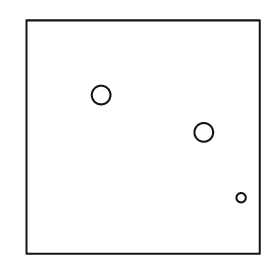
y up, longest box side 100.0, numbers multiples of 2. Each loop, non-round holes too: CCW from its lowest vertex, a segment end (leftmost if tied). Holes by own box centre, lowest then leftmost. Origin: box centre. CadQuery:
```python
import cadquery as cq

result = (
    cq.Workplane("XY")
    .moveTo(-50.0, -50.0)
    .lineTo(50.0, -50.0)
    .lineTo(50.0, 50.0)
    .lineTo(-50.0, 50.0)
    .close()
    .moveTo(42.0, -26.0)
    .circle(2.0)
    .moveTo(26.0, 2.0)
    .circle(4.0)
    .moveTo(-18.0, 18.0)
    .circle(4.0)
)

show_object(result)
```